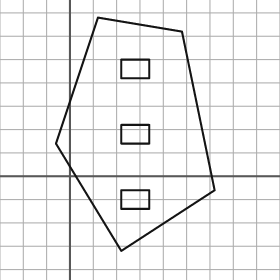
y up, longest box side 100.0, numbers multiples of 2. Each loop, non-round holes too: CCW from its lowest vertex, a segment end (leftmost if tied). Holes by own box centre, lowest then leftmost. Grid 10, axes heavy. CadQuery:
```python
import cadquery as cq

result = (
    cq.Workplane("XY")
    .moveTo(22.0, -32.0)
    .lineTo(62.0, -6.0)
    .lineTo(48.0, 62.0)
    .lineTo(12.0, 68.0)
    .lineTo(-6.0, 14.0)
    .close()
    .moveTo(22.0, -14.0)
    .lineTo(34.0, -14.0)
    .lineTo(34.0, -6.0)
    .lineTo(22.0, -6.0)
    .close()
    .moveTo(22.0, 14.0)
    .lineTo(34.0, 14.0)
    .lineTo(34.0, 22.0)
    .lineTo(22.0, 22.0)
    .close()
    .moveTo(22.0, 42.0)
    .lineTo(34.0, 42.0)
    .lineTo(34.0, 50.0)
    .lineTo(22.0, 50.0)
    .close()
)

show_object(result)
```